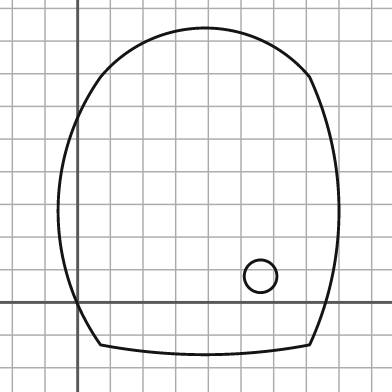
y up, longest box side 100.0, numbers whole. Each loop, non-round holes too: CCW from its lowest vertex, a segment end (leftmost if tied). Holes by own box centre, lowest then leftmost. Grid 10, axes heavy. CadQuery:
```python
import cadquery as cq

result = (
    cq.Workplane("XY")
    .moveTo(7.0, -13.0)
    .threePointArc((39.0, -16.0), (71.0, -13.0))
    .threePointArc((80.0, 28.0), (71.0, 69.0))
    .threePointArc((39.0, 84.0), (7.0, 69.0))
    .threePointArc((-6.0, 28.0), (7.0, -13.0))
    .close()
    .moveTo(56.0, 8.0)
    .circle(5.0)
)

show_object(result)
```